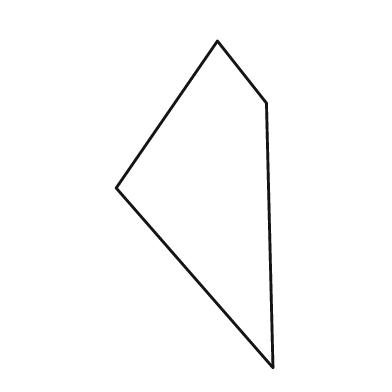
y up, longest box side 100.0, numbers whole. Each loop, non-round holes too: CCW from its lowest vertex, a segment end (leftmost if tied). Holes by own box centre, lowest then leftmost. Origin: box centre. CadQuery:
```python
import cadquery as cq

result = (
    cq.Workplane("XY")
    .moveTo(24.0, -50.0)
    .lineTo(22.0, 31.0)
    .lineTo(7.0, 50.0)
    .lineTo(-24.0, 5.0)
    .close()
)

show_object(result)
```